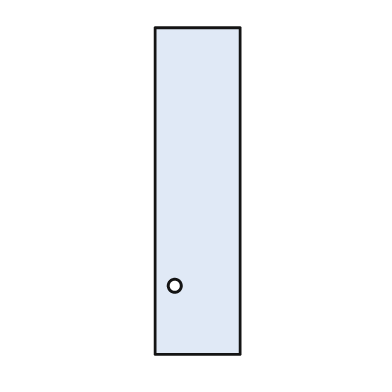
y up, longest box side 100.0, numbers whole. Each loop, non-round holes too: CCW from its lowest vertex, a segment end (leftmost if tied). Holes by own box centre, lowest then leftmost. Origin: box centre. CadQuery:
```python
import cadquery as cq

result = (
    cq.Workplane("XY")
    .moveTo(-13.0, -50.0)
    .lineTo(13.0, -50.0)
    .lineTo(13.0, 50.0)
    .lineTo(-13.0, 50.0)
    .close()
    .moveTo(-7.0, -29.0)
    .circle(2.0)
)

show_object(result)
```